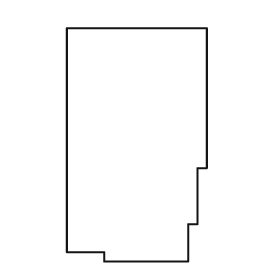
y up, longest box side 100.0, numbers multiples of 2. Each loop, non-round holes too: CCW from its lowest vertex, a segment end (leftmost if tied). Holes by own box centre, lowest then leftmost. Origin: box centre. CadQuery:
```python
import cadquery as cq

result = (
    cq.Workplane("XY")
    .moveTo(-14.0, -50.0)
    .lineTo(22.0, -50.0)
    .lineTo(22.0, -34.0)
    .lineTo(26.0, -34.0)
    .lineTo(26.0, -10.0)
    .lineTo(30.0, -10.0)
    .lineTo(30.0, 50.0)
    .lineTo(-30.0, 50.0)
    .lineTo(-30.0, -46.0)
    .lineTo(-14.0, -46.0)
    .close()
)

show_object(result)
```